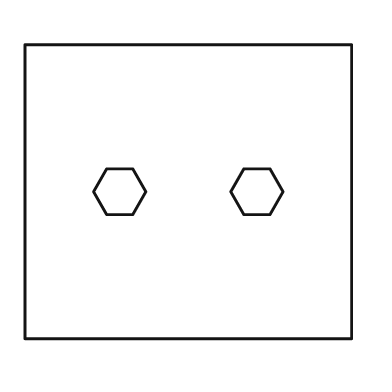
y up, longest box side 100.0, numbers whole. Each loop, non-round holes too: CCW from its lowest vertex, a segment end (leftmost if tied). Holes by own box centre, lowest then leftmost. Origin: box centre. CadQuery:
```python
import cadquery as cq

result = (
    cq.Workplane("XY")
    .moveTo(-50.0, -45.0)
    .lineTo(50.0, -45.0)
    .lineTo(50.0, 45.0)
    .lineTo(-50.0, 45.0)
    .close()
    .moveTo(-25.0, -7.0)
    .lineTo(-17.0, -7.0)
    .lineTo(-13.0, 0.0)
    .lineTo(-17.0, 7.0)
    .lineTo(-25.0, 7.0)
    .lineTo(-29.0, 0.0)
    .close()
    .moveTo(17.0, -7.0)
    .lineTo(25.0, -7.0)
    .lineTo(29.0, 0.0)
    .lineTo(25.0, 7.0)
    .lineTo(17.0, 7.0)
    .lineTo(13.0, 0.0)
    .close()
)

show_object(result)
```